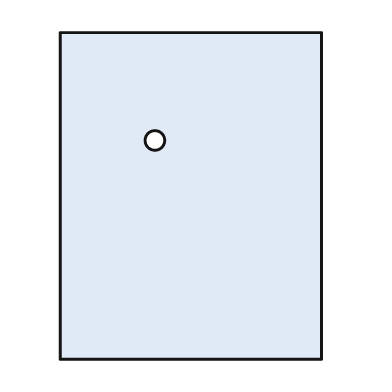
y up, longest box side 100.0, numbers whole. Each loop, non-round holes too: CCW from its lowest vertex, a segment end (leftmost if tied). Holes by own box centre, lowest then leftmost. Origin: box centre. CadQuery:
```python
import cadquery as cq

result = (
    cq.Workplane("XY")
    .moveTo(-40.0, -50.0)
    .lineTo(40.0, -50.0)
    .lineTo(40.0, 50.0)
    .lineTo(-40.0, 50.0)
    .close()
    .moveTo(-11.0, 17.0)
    .circle(3.0)
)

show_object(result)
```